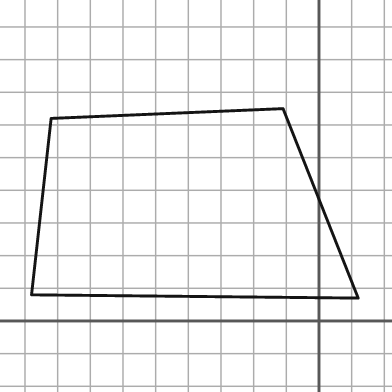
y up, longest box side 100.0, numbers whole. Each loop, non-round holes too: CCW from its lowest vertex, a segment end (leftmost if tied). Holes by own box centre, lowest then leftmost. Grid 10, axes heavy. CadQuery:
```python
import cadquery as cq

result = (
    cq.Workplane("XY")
    .moveTo(12.0, 7.0)
    .lineTo(-11.0, 65.0)
    .lineTo(-82.0, 62.0)
    .lineTo(-88.0, 8.0)
    .close()
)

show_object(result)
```